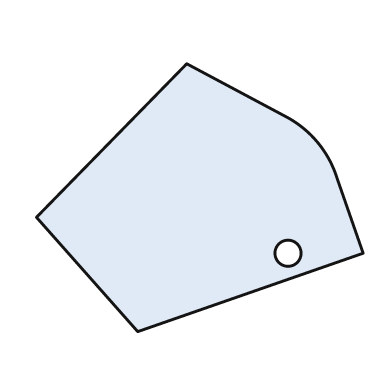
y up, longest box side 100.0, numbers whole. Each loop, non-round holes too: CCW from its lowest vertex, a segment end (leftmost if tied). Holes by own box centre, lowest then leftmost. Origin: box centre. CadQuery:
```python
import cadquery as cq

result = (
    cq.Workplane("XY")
    .moveTo(-19.0, -41.0)
    .lineTo(50.0, -17.0)
    .lineTo(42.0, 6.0)
    .threePointArc((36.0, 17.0), (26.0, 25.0))
    .lineTo(-4.0, 41.0)
    .lineTo(-50.0, -6.0)
    .close()
    .moveTo(27.0, -17.0)
    .circle(4.0)
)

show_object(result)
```